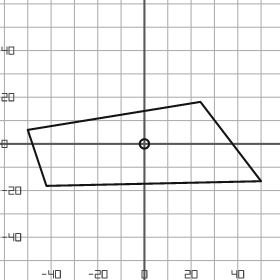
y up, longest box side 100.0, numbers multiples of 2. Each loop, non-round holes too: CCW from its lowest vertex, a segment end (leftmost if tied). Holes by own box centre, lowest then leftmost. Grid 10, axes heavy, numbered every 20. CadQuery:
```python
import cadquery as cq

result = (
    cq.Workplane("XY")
    .moveTo(-42.0, -18.0)
    .lineTo(50.0, -16.0)
    .lineTo(24.0, 18.0)
    .lineTo(-50.0, 6.0)
    .close()
    .moveTo(0.0, 0.0)
    .circle(2.0)
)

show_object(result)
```